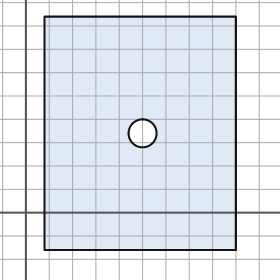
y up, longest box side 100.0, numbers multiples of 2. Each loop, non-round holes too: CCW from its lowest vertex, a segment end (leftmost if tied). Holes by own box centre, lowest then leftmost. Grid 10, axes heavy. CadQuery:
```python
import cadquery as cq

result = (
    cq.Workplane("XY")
    .moveTo(8.0, -16.0)
    .lineTo(90.0, -16.0)
    .lineTo(90.0, 84.0)
    .lineTo(8.0, 84.0)
    .close()
    .moveTo(50.0, 34.0)
    .circle(6.0)
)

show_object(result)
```